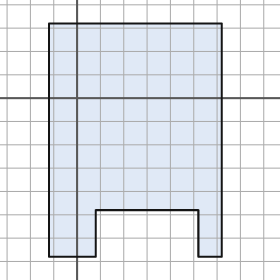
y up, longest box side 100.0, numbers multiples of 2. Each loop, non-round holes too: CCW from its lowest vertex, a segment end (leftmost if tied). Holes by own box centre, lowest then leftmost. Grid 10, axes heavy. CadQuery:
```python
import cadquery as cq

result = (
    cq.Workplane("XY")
    .moveTo(-12.0, -68.0)
    .lineTo(8.0, -68.0)
    .lineTo(8.0, -48.0)
    .lineTo(52.0, -48.0)
    .lineTo(52.0, -68.0)
    .lineTo(62.0, -68.0)
    .lineTo(62.0, 32.0)
    .lineTo(-12.0, 32.0)
    .close()
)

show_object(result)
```